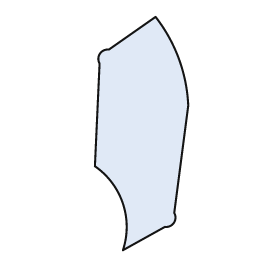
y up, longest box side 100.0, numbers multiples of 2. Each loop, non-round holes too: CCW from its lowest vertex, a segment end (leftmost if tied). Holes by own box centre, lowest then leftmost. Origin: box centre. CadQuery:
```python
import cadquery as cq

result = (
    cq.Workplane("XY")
    .moveTo(-8.0, -50.0)
    .lineTo(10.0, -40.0)
    .threePointArc((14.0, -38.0), (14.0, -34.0))
    .lineTo(20.0, 12.0)
    .threePointArc((16.0, 32.0), (6.0, 50.0))
    .lineTo(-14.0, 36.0)
    .threePointArc((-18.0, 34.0), (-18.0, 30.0))
    .lineTo(-20.0, -14.0)
    .threePointArc((-8.0, -30.0), (-8.0, -50.0))
    .close()
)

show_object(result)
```